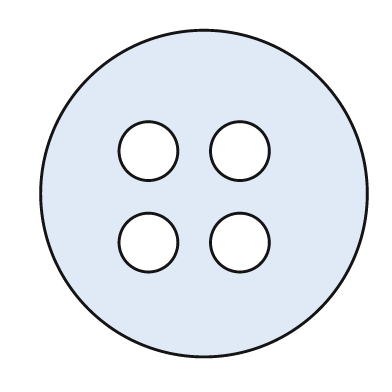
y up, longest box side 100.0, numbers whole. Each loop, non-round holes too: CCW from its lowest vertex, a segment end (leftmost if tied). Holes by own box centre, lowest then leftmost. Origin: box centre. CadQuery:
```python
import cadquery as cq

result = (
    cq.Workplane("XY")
    .moveTo(0.0, 0.0)
    .circle(50.0)
    .moveTo(-17.0, -15.0)
    .circle(9.0)
    .moveTo(11.0, -15.0)
    .circle(9.0)
    .moveTo(-17.0, 13.0)
    .circle(9.0)
    .moveTo(11.0, 13.0)
    .circle(9.0)
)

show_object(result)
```